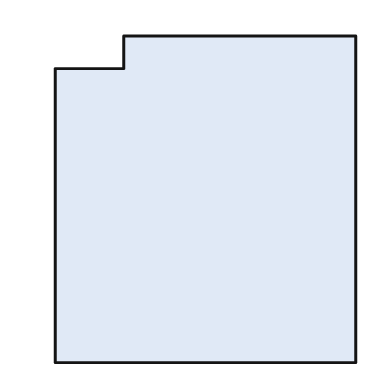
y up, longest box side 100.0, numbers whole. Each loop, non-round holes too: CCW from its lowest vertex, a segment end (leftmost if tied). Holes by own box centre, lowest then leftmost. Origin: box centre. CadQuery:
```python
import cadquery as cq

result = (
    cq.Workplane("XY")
    .moveTo(-46.0, -50.0)
    .lineTo(46.0, -50.0)
    .lineTo(46.0, 50.0)
    .lineTo(-25.0, 50.0)
    .lineTo(-25.0, 40.0)
    .lineTo(-46.0, 40.0)
    .close()
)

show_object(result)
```